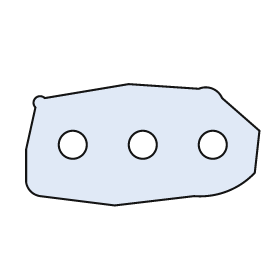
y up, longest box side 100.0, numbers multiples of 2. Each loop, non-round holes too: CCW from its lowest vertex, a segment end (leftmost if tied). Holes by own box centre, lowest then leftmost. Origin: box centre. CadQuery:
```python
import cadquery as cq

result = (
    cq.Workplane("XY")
    .moveTo(-12.0, -26.0)
    .lineTo(22.0, -22.0)
    .threePointArc((36.0, -20.0), (48.0, -12.0))
    .lineTo(50.0, 6.0)
    .lineTo(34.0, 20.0)
    .threePointArc((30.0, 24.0), (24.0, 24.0))
    .lineTo(-6.0, 26.0)
    .lineTo(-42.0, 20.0)
    .threePointArc((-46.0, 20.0), (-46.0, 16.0))
    .lineTo(-50.0, -2.0)
    .lineTo(-50.0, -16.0)
    .threePointArc((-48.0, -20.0), (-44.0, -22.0))
    .close()
    .moveTo(-30.0, 0.0)
    .circle(6.0)
    .moveTo(0.0, 0.0)
    .circle(6.0)
    .moveTo(30.0, 0.0)
    .circle(6.0)
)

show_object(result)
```